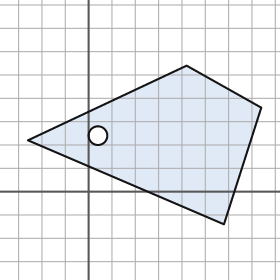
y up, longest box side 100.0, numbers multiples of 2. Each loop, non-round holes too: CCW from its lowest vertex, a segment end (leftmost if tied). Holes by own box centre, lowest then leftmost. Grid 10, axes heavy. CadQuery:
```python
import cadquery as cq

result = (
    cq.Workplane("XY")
    .moveTo(58.0, -14.0)
    .lineTo(74.0, 36.0)
    .lineTo(42.0, 54.0)
    .lineTo(-26.0, 22.0)
    .close()
    .moveTo(4.0, 24.0)
    .circle(4.0)
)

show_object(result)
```